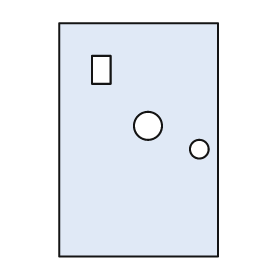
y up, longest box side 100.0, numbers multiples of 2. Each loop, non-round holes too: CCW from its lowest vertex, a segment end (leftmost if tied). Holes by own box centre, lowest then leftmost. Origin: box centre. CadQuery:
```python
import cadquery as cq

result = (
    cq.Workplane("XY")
    .moveTo(-34.0, -50.0)
    .lineTo(34.0, -50.0)
    .lineTo(34.0, 50.0)
    .lineTo(-34.0, 50.0)
    .close()
    .moveTo(26.0, -4.0)
    .circle(4.0)
    .moveTo(4.0, 6.0)
    .circle(6.0)
    .moveTo(-20.0, 24.0)
    .lineTo(-12.0, 24.0)
    .lineTo(-12.0, 36.0)
    .lineTo(-20.0, 36.0)
    .close()
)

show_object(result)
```